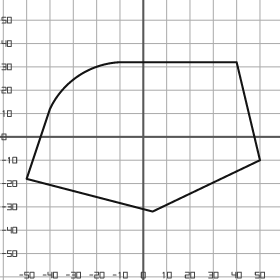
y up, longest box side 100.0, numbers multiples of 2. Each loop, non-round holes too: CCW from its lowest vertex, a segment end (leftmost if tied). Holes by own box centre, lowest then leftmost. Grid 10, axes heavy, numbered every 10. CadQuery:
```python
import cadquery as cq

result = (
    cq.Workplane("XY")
    .moveTo(4.0, -32.0)
    .lineTo(50.0, -10.0)
    .lineTo(40.0, 32.0)
    .lineTo(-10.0, 32.0)
    .threePointArc((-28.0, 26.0), (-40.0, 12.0))
    .lineTo(-50.0, -18.0)
    .close()
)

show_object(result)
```